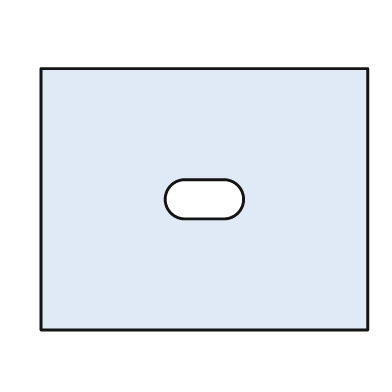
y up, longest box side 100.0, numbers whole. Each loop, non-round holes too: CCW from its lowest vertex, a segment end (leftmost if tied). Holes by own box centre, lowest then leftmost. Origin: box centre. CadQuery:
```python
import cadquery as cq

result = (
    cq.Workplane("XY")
    .moveTo(-50.0, -40.0)
    .lineTo(50.0, -40.0)
    .lineTo(50.0, 40.0)
    .lineTo(-50.0, 40.0)
    .close()
    .moveTo(-6.0, -6.0)
    .lineTo(6.0, -6.0)
    .threePointArc((12.0, 0.0), (6.0, 6.0))
    .lineTo(-6.0, 6.0)
    .threePointArc((-12.0, 0.0), (-6.0, -6.0))
    .close()
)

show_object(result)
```